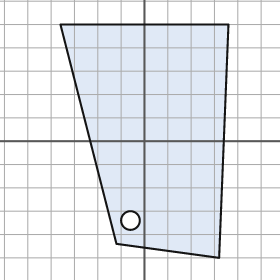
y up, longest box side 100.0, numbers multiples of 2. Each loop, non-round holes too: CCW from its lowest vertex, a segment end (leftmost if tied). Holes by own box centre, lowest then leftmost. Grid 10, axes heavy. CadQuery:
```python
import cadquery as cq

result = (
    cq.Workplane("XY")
    .moveTo(32.0, -50.0)
    .lineTo(36.0, 50.0)
    .lineTo(-36.0, 50.0)
    .lineTo(-12.0, -44.0)
    .close()
    .moveTo(-6.0, -34.0)
    .circle(4.0)
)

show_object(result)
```